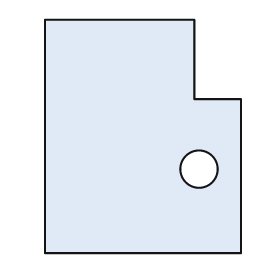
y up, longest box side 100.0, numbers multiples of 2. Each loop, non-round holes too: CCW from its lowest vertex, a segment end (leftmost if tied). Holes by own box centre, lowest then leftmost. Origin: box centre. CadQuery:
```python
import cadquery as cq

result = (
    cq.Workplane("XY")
    .moveTo(-42.0, -50.0)
    .lineTo(42.0, -50.0)
    .lineTo(42.0, 16.0)
    .lineTo(22.0, 16.0)
    .lineTo(22.0, 50.0)
    .lineTo(-42.0, 50.0)
    .close()
    .moveTo(24.0, -14.0)
    .circle(8.0)
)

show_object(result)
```